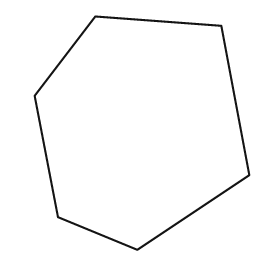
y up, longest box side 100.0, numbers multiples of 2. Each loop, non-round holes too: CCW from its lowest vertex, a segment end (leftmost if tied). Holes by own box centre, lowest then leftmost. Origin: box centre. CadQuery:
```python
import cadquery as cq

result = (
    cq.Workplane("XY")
    .moveTo(-2.0, -50.0)
    .lineTo(46.0, -18.0)
    .lineTo(34.0, 46.0)
    .lineTo(-20.0, 50.0)
    .lineTo(-46.0, 16.0)
    .lineTo(-36.0, -36.0)
    .close()
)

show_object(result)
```